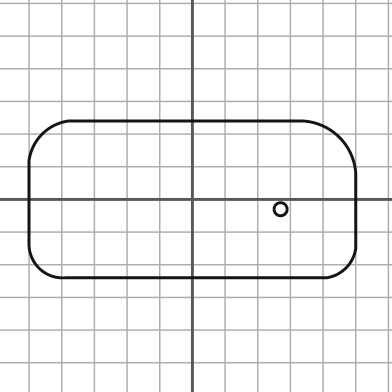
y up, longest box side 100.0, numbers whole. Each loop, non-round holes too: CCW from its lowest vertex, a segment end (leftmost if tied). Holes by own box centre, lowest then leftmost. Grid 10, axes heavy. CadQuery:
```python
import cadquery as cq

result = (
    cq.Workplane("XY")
    .moveTo(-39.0, -24.0)
    .lineTo(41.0, -24.0)
    .threePointArc((47.0, -21.0), (50.0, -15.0))
    .lineTo(50.0, 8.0)
    .threePointArc((45.0, 19.0), (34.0, 24.0))
    .lineTo(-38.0, 24.0)
    .threePointArc((-46.0, 20.0), (-50.0, 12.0))
    .lineTo(-50.0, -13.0)
    .threePointArc((-47.0, -21.0), (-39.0, -24.0))
    .close()
    .moveTo(27.0, -3.0)
    .circle(2.0)
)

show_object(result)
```